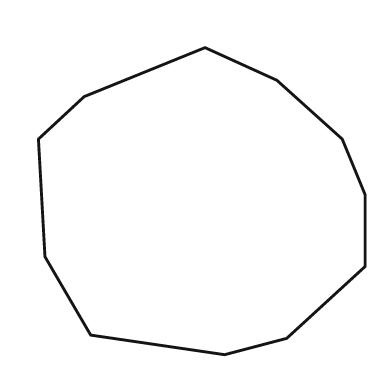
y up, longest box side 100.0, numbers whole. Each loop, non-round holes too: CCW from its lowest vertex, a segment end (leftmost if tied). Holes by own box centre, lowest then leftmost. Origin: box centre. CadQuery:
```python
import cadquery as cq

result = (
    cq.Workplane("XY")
    .moveTo(7.0, -47.0)
    .lineTo(26.0, -42.0)
    .lineTo(50.0, -20.0)
    .lineTo(50.0, 2.0)
    .lineTo(43.0, 19.0)
    .lineTo(23.0, 37.0)
    .lineTo(1.0, 47.0)
    .lineTo(-36.0, 32.0)
    .lineTo(-50.0, 19.0)
    .lineTo(-48.0, -17.0)
    .lineTo(-34.0, -41.0)
    .close()
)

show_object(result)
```